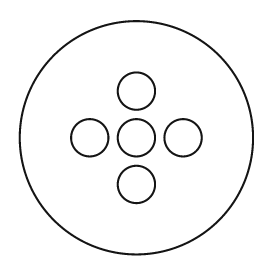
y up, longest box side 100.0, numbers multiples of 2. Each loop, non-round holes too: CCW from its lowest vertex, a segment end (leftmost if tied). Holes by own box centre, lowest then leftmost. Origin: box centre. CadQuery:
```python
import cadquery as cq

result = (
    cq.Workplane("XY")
    .moveTo(0.0, 0.0)
    .circle(50.0)
    .moveTo(0.0, -20.0)
    .circle(8.0)
    .moveTo(-20.0, 0.0)
    .circle(8.0)
    .moveTo(0.0, 0.0)
    .circle(8.0)
    .moveTo(20.0, 0.0)
    .circle(8.0)
    .moveTo(0.0, 20.0)
    .circle(8.0)
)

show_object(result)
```